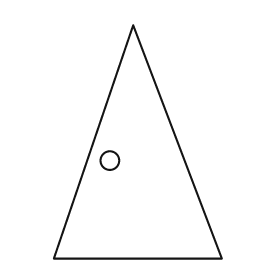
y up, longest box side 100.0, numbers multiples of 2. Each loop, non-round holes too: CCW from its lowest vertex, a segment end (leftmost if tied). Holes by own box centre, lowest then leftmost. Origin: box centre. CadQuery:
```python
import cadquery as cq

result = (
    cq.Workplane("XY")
    .moveTo(-36.0, -50.0)
    .lineTo(36.0, -50.0)
    .lineTo(-2.0, 50.0)
    .close()
    .moveTo(-12.0, -8.0)
    .circle(4.0)
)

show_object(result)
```